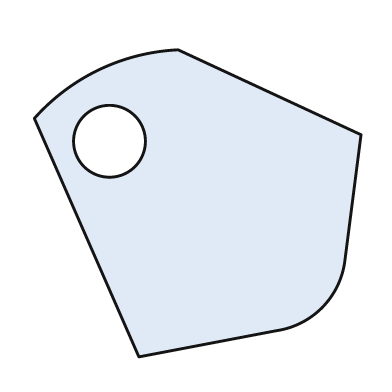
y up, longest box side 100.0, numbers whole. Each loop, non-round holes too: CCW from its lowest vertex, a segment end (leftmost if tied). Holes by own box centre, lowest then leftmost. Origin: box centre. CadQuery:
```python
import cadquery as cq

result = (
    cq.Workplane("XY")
    .moveTo(-18.0, -47.0)
    .lineTo(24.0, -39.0)
    .threePointArc((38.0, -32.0), (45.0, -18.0))
    .lineTo(50.0, 21.0)
    .lineTo(-6.0, 47.0)
    .threePointArc((-30.0, 41.0), (-50.0, 26.0))
    .close()
    .moveTo(-27.0, 19.0)
    .circle(11.0)
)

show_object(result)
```